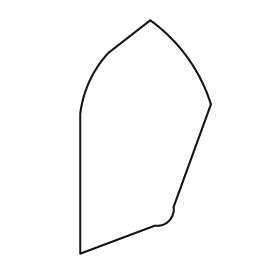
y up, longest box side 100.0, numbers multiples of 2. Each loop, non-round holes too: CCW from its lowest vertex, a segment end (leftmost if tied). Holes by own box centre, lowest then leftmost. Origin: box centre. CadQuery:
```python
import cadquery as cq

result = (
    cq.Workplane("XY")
    .moveTo(-28.0, -50.0)
    .lineTo(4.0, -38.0)
    .threePointArc((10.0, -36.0), (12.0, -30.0))
    .lineTo(28.0, 14.0)
    .threePointArc((18.0, 34.0), (2.0, 50.0))
    .lineTo(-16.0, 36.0)
    .threePointArc((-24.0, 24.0), (-28.0, 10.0))
    .close()
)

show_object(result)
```